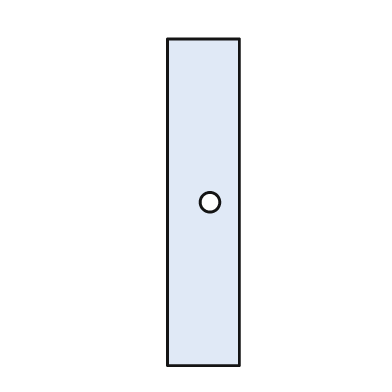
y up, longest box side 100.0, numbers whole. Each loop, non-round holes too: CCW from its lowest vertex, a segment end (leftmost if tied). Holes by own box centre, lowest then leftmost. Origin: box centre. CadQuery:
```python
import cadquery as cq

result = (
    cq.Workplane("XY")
    .moveTo(-11.0, -50.0)
    .lineTo(11.0, -50.0)
    .lineTo(11.0, 50.0)
    .lineTo(-11.0, 50.0)
    .close()
    .moveTo(2.0, 0.0)
    .circle(3.0)
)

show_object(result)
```